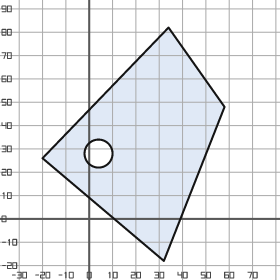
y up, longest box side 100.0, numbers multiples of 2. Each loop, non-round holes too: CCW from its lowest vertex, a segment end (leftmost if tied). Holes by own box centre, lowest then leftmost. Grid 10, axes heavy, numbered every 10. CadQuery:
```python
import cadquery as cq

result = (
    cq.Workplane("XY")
    .moveTo(32.0, -18.0)
    .lineTo(58.0, 48.0)
    .lineTo(34.0, 82.0)
    .lineTo(-20.0, 26.0)
    .close()
    .moveTo(4.0, 28.0)
    .circle(6.0)
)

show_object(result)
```